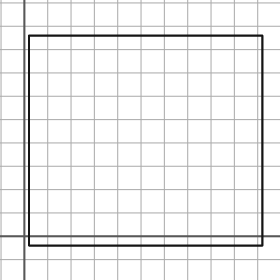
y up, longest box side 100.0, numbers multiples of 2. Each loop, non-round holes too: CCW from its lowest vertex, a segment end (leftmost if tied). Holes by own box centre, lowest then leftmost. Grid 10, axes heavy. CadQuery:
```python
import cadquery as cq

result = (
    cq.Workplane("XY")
    .moveTo(2.0, -4.0)
    .lineTo(102.0, -4.0)
    .lineTo(102.0, 86.0)
    .lineTo(2.0, 86.0)
    .close()
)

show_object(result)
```